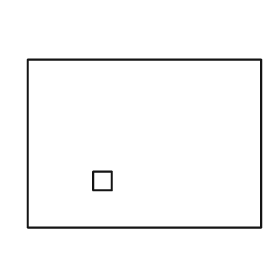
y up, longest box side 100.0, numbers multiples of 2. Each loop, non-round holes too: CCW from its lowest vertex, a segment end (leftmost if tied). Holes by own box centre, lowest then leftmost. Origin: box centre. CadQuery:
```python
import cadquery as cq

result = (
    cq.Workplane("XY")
    .moveTo(-50.0, -36.0)
    .lineTo(50.0, -36.0)
    .lineTo(50.0, 36.0)
    .lineTo(-50.0, 36.0)
    .close()
    .moveTo(-22.0, -20.0)
    .lineTo(-14.0, -20.0)
    .lineTo(-14.0, -12.0)
    .lineTo(-22.0, -12.0)
    .close()
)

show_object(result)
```